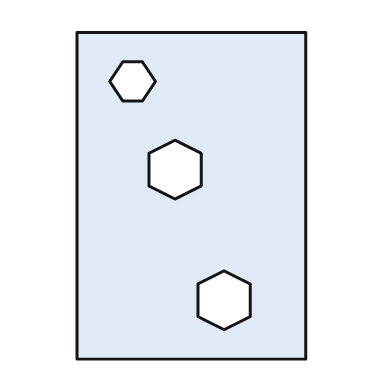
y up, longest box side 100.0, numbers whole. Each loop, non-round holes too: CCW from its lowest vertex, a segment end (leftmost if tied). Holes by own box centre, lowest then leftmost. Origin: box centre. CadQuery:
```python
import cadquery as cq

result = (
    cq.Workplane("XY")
    .moveTo(-35.0, -50.0)
    .lineTo(35.0, -50.0)
    .lineTo(35.0, 50.0)
    .lineTo(-35.0, 50.0)
    .close()
    .moveTo(10.0, -41.0)
    .lineTo(18.0, -37.0)
    .lineTo(18.0, -27.0)
    .lineTo(10.0, -23.0)
    .lineTo(2.0, -27.0)
    .lineTo(2.0, -37.0)
    .close()
    .moveTo(-5.0, -1.0)
    .lineTo(3.0, 3.0)
    .lineTo(3.0, 13.0)
    .lineTo(-5.0, 17.0)
    .lineTo(-13.0, 13.0)
    .lineTo(-13.0, 3.0)
    .close()
    .moveTo(-21.0, 29.0)
    .lineTo(-15.0, 29.0)
    .lineTo(-11.0, 35.0)
    .lineTo(-15.0, 41.0)
    .lineTo(-21.0, 41.0)
    .lineTo(-25.0, 35.0)
    .close()
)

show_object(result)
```